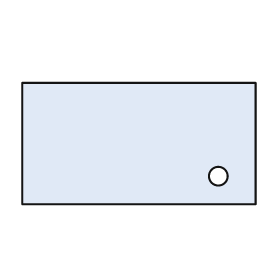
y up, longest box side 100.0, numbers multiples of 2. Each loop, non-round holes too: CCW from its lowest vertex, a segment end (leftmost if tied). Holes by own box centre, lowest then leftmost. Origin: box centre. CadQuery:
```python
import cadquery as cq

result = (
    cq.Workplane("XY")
    .moveTo(-50.0, -26.0)
    .lineTo(50.0, -26.0)
    .lineTo(50.0, 26.0)
    .lineTo(-50.0, 26.0)
    .close()
    .moveTo(34.0, -14.0)
    .circle(4.0)
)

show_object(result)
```